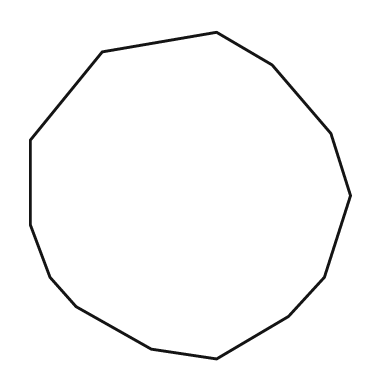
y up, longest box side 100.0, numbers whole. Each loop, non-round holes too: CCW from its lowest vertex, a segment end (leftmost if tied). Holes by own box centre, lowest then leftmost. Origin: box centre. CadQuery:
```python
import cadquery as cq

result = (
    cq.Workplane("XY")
    .moveTo(8.0, -50.0)
    .lineTo(30.0, -37.0)
    .lineTo(41.0, -25.0)
    .lineTo(49.0, 0.0)
    .lineTo(43.0, 19.0)
    .lineTo(25.0, 40.0)
    .lineTo(8.0, 50.0)
    .lineTo(-27.0, 44.0)
    .lineTo(-49.0, 17.0)
    .lineTo(-49.0, -9.0)
    .lineTo(-43.0, -25.0)
    .lineTo(-35.0, -34.0)
    .lineTo(-12.0, -47.0)
    .close()
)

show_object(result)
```